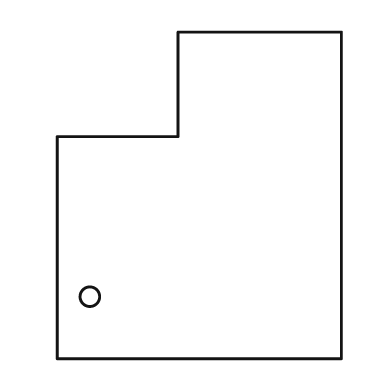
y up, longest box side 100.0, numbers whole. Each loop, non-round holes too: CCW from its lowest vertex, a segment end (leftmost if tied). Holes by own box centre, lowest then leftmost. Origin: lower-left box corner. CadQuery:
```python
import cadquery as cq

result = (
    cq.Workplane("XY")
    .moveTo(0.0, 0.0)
    .lineTo(87.0, 0.0)
    .lineTo(87.0, 100.0)
    .lineTo(37.0, 100.0)
    .lineTo(37.0, 68.0)
    .lineTo(0.0, 68.0)
    .close()
    .moveTo(10.0, 19.0)
    .circle(3.0)
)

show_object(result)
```